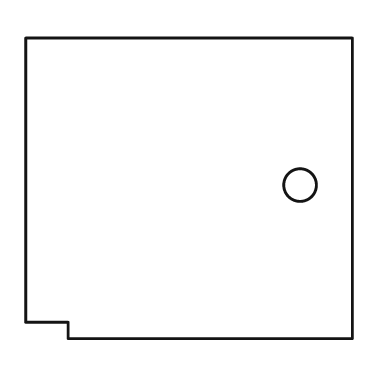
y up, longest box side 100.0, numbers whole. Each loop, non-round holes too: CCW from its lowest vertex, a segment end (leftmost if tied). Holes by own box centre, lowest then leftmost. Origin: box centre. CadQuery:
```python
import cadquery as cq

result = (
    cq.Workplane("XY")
    .moveTo(-37.0, -46.0)
    .lineTo(50.0, -46.0)
    .lineTo(50.0, 46.0)
    .lineTo(-50.0, 46.0)
    .lineTo(-50.0, -41.0)
    .lineTo(-37.0, -41.0)
    .close()
    .moveTo(34.0, 1.0)
    .circle(5.0)
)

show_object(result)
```